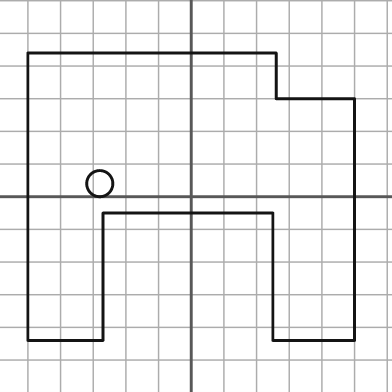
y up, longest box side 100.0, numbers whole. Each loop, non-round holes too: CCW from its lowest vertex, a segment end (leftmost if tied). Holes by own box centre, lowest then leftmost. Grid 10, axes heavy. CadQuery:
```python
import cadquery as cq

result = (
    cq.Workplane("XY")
    .moveTo(-50.0, -44.0)
    .lineTo(-27.0, -44.0)
    .lineTo(-27.0, -5.0)
    .lineTo(25.0, -5.0)
    .lineTo(25.0, -44.0)
    .lineTo(50.0, -44.0)
    .lineTo(50.0, 30.0)
    .lineTo(26.0, 30.0)
    .lineTo(26.0, 44.0)
    .lineTo(-50.0, 44.0)
    .close()
    .moveTo(-28.0, 4.0)
    .circle(4.0)
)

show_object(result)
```